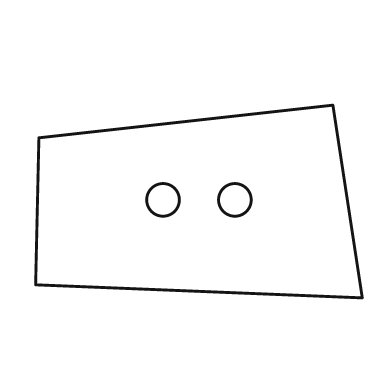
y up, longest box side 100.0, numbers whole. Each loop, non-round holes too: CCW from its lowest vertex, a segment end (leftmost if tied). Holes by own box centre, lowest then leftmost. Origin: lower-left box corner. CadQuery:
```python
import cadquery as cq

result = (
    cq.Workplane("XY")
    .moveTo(100.0, 0.0)
    .lineTo(91.0, 59.0)
    .lineTo(1.0, 49.0)
    .lineTo(0.0, 4.0)
    .close()
    .moveTo(39.0, 30.0)
    .circle(5.0)
    .moveTo(61.0, 30.0)
    .circle(5.0)
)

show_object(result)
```